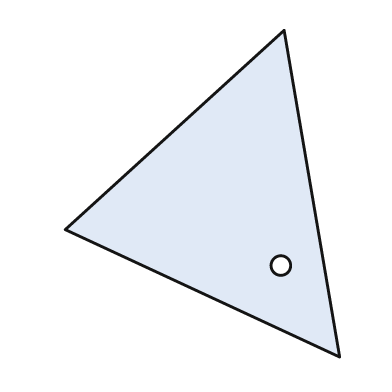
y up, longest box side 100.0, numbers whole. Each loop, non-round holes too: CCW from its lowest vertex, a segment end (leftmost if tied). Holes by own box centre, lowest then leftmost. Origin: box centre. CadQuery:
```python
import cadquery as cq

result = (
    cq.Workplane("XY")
    .moveTo(42.0, -50.0)
    .lineTo(25.0, 50.0)
    .lineTo(-42.0, -11.0)
    .close()
    .moveTo(24.0, -22.0)
    .circle(3.0)
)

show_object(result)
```